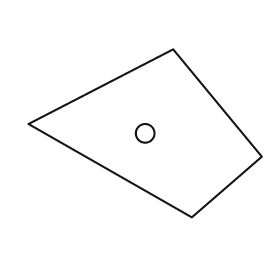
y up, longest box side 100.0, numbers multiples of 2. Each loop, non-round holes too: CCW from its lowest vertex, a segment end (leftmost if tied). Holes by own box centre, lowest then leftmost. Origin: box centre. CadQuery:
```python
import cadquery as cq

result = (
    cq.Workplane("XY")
    .moveTo(20.0, -36.0)
    .lineTo(50.0, -10.0)
    .lineTo(12.0, 36.0)
    .lineTo(-50.0, 4.0)
    .close()
    .moveTo(0.0, 0.0)
    .circle(4.0)
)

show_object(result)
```